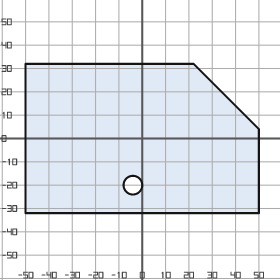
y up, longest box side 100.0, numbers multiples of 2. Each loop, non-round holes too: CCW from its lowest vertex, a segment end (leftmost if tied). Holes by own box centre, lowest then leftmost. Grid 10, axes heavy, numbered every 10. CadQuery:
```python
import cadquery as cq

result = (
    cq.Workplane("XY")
    .moveTo(-50.0, -32.0)
    .lineTo(50.0, -32.0)
    .lineTo(50.0, 4.0)
    .lineTo(22.0, 32.0)
    .lineTo(-50.0, 32.0)
    .close()
    .moveTo(-4.0, -20.0)
    .circle(4.0)
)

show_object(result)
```